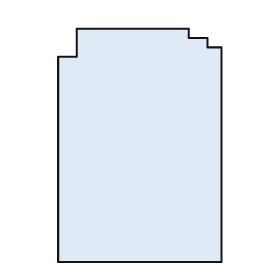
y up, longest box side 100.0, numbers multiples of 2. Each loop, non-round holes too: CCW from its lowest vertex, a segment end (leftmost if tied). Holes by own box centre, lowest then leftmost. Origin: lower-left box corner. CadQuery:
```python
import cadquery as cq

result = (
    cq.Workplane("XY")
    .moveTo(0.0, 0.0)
    .lineTo(70.0, 0.0)
    .lineTo(70.0, 92.0)
    .lineTo(64.0, 92.0)
    .lineTo(64.0, 96.0)
    .lineTo(56.0, 96.0)
    .lineTo(56.0, 100.0)
    .lineTo(8.0, 100.0)
    .lineTo(8.0, 88.0)
    .lineTo(0.0, 88.0)
    .close()
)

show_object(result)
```